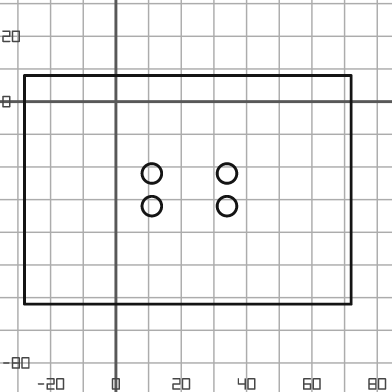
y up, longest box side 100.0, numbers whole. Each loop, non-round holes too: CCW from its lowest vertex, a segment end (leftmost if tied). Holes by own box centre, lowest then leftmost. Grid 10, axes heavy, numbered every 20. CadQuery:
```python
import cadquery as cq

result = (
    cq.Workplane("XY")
    .moveTo(-28.0, -62.0)
    .lineTo(72.0, -62.0)
    .lineTo(72.0, 8.0)
    .lineTo(-28.0, 8.0)
    .close()
    .moveTo(11.0, -32.0)
    .circle(3.0)
    .moveTo(34.0, -32.0)
    .circle(3.0)
    .moveTo(11.0, -22.0)
    .circle(3.0)
    .moveTo(34.0, -22.0)
    .circle(3.0)
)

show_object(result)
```